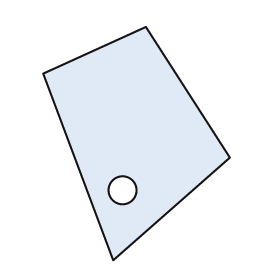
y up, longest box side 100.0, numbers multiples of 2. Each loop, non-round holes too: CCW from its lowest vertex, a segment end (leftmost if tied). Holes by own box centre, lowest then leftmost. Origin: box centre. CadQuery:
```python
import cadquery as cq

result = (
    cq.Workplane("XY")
    .moveTo(-10.0, -50.0)
    .lineTo(40.0, -6.0)
    .lineTo(4.0, 50.0)
    .lineTo(-40.0, 30.0)
    .close()
    .moveTo(-6.0, -20.0)
    .circle(6.0)
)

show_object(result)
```